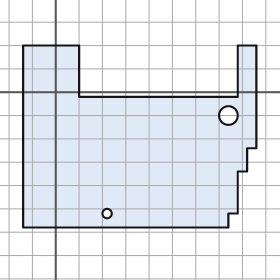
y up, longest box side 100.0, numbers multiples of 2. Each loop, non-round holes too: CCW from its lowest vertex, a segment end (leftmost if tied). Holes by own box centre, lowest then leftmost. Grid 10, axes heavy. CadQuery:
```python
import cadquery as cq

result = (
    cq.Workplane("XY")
    .moveTo(-14.0, -58.0)
    .lineTo(74.0, -58.0)
    .lineTo(74.0, -52.0)
    .lineTo(78.0, -52.0)
    .lineTo(78.0, -34.0)
    .lineTo(82.0, -34.0)
    .lineTo(82.0, -24.0)
    .lineTo(86.0, -24.0)
    .lineTo(86.0, 20.0)
    .lineTo(78.0, 20.0)
    .lineTo(78.0, -2.0)
    .lineTo(10.0, -2.0)
    .lineTo(10.0, 20.0)
    .lineTo(-14.0, 20.0)
    .close()
    .moveTo(22.0, -52.0)
    .circle(2.0)
    .moveTo(74.0, -10.0)
    .circle(4.0)
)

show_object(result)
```